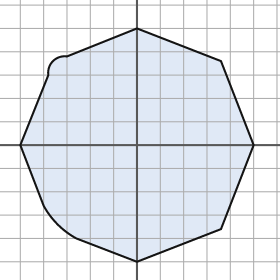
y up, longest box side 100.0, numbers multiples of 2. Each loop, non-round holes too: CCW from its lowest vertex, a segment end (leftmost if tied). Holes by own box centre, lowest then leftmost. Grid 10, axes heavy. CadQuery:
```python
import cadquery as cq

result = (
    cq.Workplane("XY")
    .moveTo(0.0, -50.0)
    .lineTo(36.0, -36.0)
    .lineTo(50.0, 0.0)
    .lineTo(36.0, 36.0)
    .lineTo(0.0, 50.0)
    .lineTo(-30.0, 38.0)
    .threePointArc((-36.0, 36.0), (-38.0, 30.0))
    .lineTo(-50.0, 0.0)
    .lineTo(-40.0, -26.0)
    .threePointArc((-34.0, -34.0), (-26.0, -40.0))
    .close()
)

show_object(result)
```